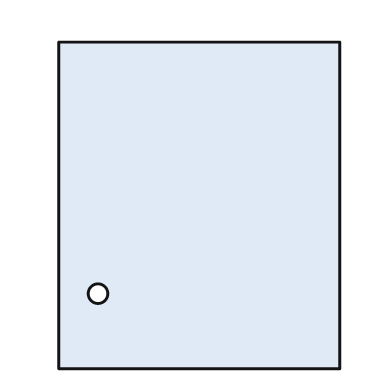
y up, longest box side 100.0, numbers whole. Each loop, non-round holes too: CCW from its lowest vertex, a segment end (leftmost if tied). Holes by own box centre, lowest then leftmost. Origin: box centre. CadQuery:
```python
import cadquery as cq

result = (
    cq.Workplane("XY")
    .moveTo(-43.0, -50.0)
    .lineTo(43.0, -50.0)
    .lineTo(43.0, 50.0)
    .lineTo(-43.0, 50.0)
    .close()
    .moveTo(-31.0, -27.0)
    .circle(3.0)
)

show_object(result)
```